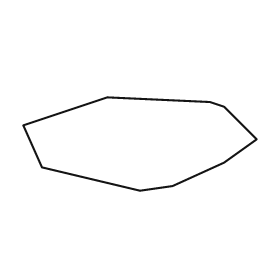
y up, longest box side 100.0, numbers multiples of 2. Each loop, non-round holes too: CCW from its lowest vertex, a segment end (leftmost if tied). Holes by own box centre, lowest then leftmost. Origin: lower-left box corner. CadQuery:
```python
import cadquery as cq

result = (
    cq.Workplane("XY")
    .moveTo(50.0, 0.0)
    .lineTo(64.0, 2.0)
    .lineTo(86.0, 12.0)
    .lineTo(100.0, 22.0)
    .lineTo(86.0, 36.0)
    .lineTo(80.0, 38.0)
    .lineTo(36.0, 40.0)
    .lineTo(0.0, 28.0)
    .lineTo(8.0, 10.0)
    .close()
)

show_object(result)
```